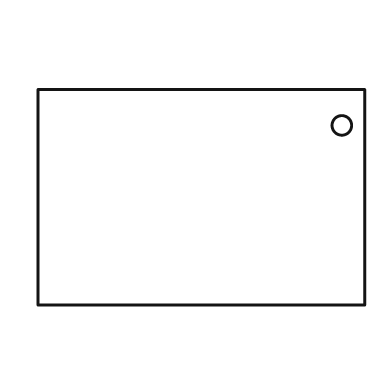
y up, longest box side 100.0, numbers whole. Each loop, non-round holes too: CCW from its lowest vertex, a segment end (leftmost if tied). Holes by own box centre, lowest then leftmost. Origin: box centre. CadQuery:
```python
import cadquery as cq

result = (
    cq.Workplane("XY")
    .moveTo(-50.0, -33.0)
    .lineTo(50.0, -33.0)
    .lineTo(50.0, 33.0)
    .lineTo(-50.0, 33.0)
    .close()
    .moveTo(43.0, 22.0)
    .circle(3.0)
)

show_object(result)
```